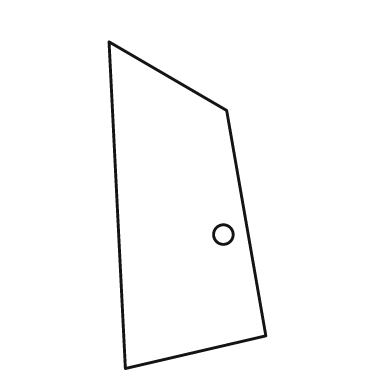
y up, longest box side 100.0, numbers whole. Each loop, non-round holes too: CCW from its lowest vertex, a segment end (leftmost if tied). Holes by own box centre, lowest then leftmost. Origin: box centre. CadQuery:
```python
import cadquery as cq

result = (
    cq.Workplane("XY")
    .moveTo(-19.0, -50.0)
    .lineTo(24.0, -40.0)
    .lineTo(12.0, 29.0)
    .lineTo(-24.0, 50.0)
    .close()
    .moveTo(11.0, -9.0)
    .circle(3.0)
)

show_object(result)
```